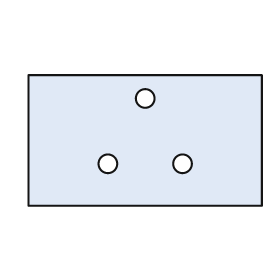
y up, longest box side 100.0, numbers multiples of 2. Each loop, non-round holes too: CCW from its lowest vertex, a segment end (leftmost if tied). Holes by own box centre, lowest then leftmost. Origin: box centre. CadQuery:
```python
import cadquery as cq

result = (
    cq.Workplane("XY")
    .moveTo(-50.0, -28.0)
    .lineTo(50.0, -28.0)
    .lineTo(50.0, 28.0)
    .lineTo(-50.0, 28.0)
    .close()
    .moveTo(-16.0, -10.0)
    .circle(4.0)
    .moveTo(16.0, -10.0)
    .circle(4.0)
    .moveTo(0.0, 18.0)
    .circle(4.0)
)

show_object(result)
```